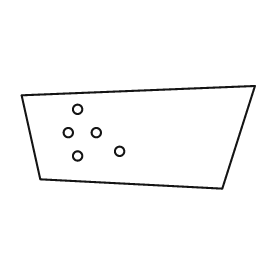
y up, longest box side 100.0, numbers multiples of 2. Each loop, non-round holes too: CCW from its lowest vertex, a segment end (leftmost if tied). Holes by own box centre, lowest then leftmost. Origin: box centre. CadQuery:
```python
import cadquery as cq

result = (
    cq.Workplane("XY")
    .moveTo(36.0, -22.0)
    .lineTo(50.0, 22.0)
    .lineTo(-50.0, 18.0)
    .lineTo(-42.0, -18.0)
    .close()
    .moveTo(-26.0, -8.0)
    .circle(2.0)
    .moveTo(-8.0, -6.0)
    .circle(2.0)
    .moveTo(-30.0, 2.0)
    .circle(2.0)
    .moveTo(-18.0, 2.0)
    .circle(2.0)
    .moveTo(-26.0, 12.0)
    .circle(2.0)
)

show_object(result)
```